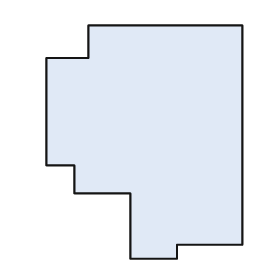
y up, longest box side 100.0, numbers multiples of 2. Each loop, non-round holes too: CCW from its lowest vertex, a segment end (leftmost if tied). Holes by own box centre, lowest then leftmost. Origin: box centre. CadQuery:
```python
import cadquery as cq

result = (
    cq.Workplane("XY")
    .moveTo(-6.0, -50.0)
    .lineTo(14.0, -50.0)
    .lineTo(14.0, -44.0)
    .lineTo(42.0, -44.0)
    .lineTo(42.0, 50.0)
    .lineTo(-24.0, 50.0)
    .lineTo(-24.0, 36.0)
    .lineTo(-42.0, 36.0)
    .lineTo(-42.0, -10.0)
    .lineTo(-30.0, -10.0)
    .lineTo(-30.0, -22.0)
    .lineTo(-6.0, -22.0)
    .close()
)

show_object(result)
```